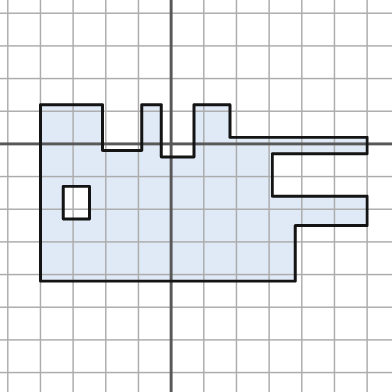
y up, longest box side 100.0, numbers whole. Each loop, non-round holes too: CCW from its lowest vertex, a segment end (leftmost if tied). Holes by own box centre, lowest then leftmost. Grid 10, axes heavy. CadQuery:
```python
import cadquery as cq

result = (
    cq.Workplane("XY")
    .moveTo(-40.0, -42.0)
    .lineTo(38.0, -42.0)
    .lineTo(38.0, -25.0)
    .lineTo(60.0, -25.0)
    .lineTo(60.0, -16.0)
    .lineTo(31.0, -16.0)
    .lineTo(31.0, -3.0)
    .lineTo(60.0, -3.0)
    .lineTo(60.0, 2.0)
    .lineTo(18.0, 2.0)
    .lineTo(18.0, 12.0)
    .lineTo(7.0, 12.0)
    .lineTo(7.0, -4.0)
    .lineTo(-3.0, -4.0)
    .lineTo(-3.0, 12.0)
    .lineTo(-9.0, 12.0)
    .lineTo(-9.0, -2.0)
    .lineTo(-21.0, -2.0)
    .lineTo(-21.0, 12.0)
    .lineTo(-40.0, 12.0)
    .close()
    .moveTo(-33.0, -23.0)
    .lineTo(-25.0, -23.0)
    .lineTo(-25.0, -13.0)
    .lineTo(-33.0, -13.0)
    .close()
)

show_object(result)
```